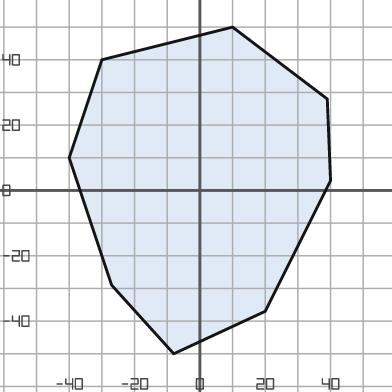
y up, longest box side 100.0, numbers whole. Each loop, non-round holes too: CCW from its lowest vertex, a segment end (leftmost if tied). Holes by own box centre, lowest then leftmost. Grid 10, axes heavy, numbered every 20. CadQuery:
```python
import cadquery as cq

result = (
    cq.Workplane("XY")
    .moveTo(-8.0, -50.0)
    .lineTo(20.0, -37.0)
    .lineTo(40.0, 3.0)
    .lineTo(39.0, 28.0)
    .lineTo(10.0, 50.0)
    .lineTo(-30.0, 40.0)
    .lineTo(-40.0, 10.0)
    .lineTo(-27.0, -29.0)
    .close()
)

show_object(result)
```